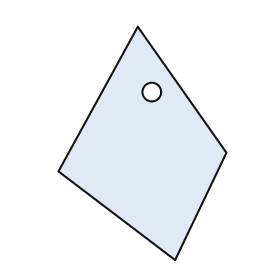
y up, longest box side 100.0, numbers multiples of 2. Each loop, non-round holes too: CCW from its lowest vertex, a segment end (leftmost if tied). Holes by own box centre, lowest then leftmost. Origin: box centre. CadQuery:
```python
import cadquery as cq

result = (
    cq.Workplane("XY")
    .moveTo(14.0, -50.0)
    .lineTo(36.0, -4.0)
    .lineTo(-2.0, 50.0)
    .lineTo(-36.0, -12.0)
    .close()
    .moveTo(4.0, 22.0)
    .circle(4.0)
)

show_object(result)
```